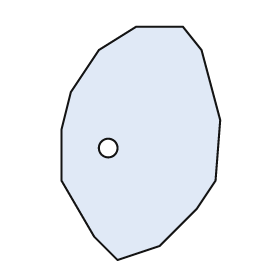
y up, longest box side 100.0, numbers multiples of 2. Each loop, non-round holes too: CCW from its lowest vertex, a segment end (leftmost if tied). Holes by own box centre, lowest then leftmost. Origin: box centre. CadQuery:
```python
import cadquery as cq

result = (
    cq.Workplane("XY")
    .moveTo(-10.0, -50.0)
    .lineTo(8.0, -44.0)
    .lineTo(24.0, -28.0)
    .lineTo(32.0, -16.0)
    .lineTo(34.0, 10.0)
    .lineTo(26.0, 40.0)
    .lineTo(18.0, 50.0)
    .lineTo(-2.0, 50.0)
    .lineTo(-18.0, 40.0)
    .lineTo(-30.0, 22.0)
    .lineTo(-34.0, 6.0)
    .lineTo(-34.0, -16.0)
    .lineTo(-20.0, -40.0)
    .close()
    .moveTo(-14.0, -2.0)
    .circle(4.0)
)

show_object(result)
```